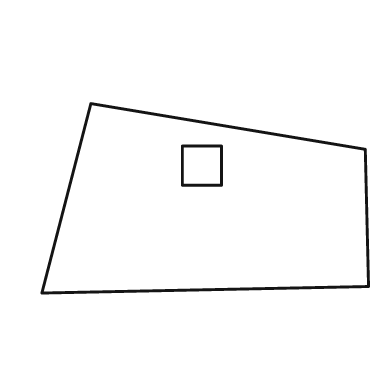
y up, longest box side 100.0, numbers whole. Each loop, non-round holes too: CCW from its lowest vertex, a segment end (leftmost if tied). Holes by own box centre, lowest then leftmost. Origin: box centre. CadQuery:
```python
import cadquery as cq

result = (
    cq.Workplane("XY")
    .moveTo(-50.0, -29.0)
    .lineTo(50.0, -27.0)
    .lineTo(49.0, 15.0)
    .lineTo(-35.0, 29.0)
    .close()
    .moveTo(-7.0, 4.0)
    .lineTo(5.0, 4.0)
    .lineTo(5.0, 16.0)
    .lineTo(-7.0, 16.0)
    .close()
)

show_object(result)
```